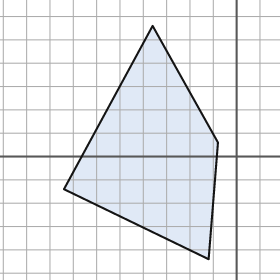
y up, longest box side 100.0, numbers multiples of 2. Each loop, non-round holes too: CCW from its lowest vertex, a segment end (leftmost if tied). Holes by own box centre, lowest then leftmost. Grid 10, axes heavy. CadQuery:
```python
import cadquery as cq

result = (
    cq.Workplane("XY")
    .moveTo(-12.0, -44.0)
    .lineTo(-8.0, 6.0)
    .lineTo(-36.0, 56.0)
    .lineTo(-74.0, -14.0)
    .close()
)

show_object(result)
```